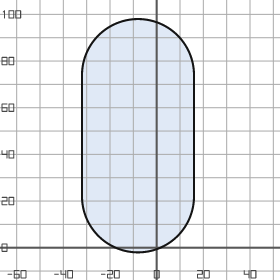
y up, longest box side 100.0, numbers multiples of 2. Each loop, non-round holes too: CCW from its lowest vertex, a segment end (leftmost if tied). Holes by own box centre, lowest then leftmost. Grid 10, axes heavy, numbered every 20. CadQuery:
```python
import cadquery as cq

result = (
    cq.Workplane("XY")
    .moveTo(-32.0, 22.0)
    .threePointArc((-8.0, -2.0), (16.0, 22.0))
    .lineTo(16.0, 74.0)
    .threePointArc((-8.0, 98.0), (-32.0, 74.0))
    .close()
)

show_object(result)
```